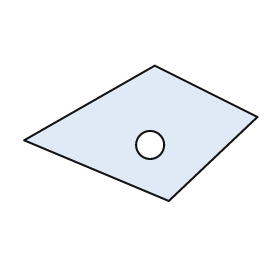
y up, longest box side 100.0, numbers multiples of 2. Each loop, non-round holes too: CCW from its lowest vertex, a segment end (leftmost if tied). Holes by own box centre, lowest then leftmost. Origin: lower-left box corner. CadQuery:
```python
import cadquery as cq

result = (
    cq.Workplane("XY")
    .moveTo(62.0, 0.0)
    .lineTo(100.0, 36.0)
    .lineTo(56.0, 58.0)
    .lineTo(0.0, 26.0)
    .close()
    .moveTo(54.0, 24.0)
    .circle(6.0)
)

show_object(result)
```